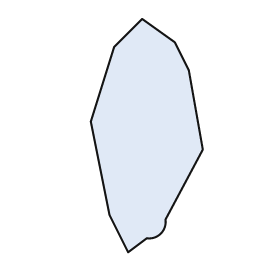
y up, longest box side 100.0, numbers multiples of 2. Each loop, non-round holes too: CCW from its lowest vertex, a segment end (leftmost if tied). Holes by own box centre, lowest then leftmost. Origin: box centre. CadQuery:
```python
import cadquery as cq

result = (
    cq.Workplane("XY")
    .moveTo(-8.0, -50.0)
    .lineTo(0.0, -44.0)
    .threePointArc((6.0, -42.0), (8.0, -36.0))
    .lineTo(24.0, -6.0)
    .lineTo(18.0, 28.0)
    .lineTo(12.0, 40.0)
    .lineTo(-2.0, 50.0)
    .lineTo(-14.0, 38.0)
    .lineTo(-24.0, 6.0)
    .lineTo(-16.0, -34.0)
    .close()
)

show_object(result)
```